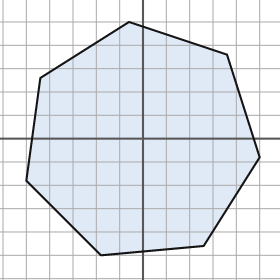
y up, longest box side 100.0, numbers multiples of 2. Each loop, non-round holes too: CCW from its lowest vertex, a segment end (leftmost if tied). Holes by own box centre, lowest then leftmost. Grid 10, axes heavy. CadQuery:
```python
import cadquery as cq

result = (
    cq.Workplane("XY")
    .moveTo(-18.0, -50.0)
    .lineTo(26.0, -46.0)
    .lineTo(50.0, -8.0)
    .lineTo(36.0, 36.0)
    .lineTo(-6.0, 50.0)
    .lineTo(-44.0, 26.0)
    .lineTo(-50.0, -18.0)
    .close()
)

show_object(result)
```